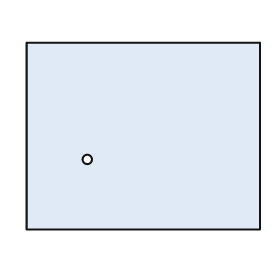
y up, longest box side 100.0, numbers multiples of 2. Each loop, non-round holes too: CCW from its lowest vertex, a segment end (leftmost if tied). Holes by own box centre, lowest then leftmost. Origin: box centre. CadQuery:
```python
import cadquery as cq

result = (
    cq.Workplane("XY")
    .moveTo(-50.0, -40.0)
    .lineTo(50.0, -40.0)
    .lineTo(50.0, 40.0)
    .lineTo(-50.0, 40.0)
    .close()
    .moveTo(-24.0, -10.0)
    .circle(2.0)
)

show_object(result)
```